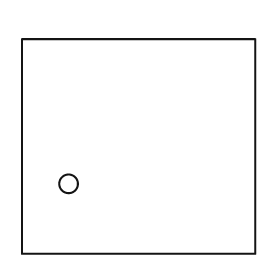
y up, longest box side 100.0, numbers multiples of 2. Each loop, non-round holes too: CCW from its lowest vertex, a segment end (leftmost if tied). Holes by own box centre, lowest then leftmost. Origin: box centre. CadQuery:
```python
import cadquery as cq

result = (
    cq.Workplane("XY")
    .moveTo(-50.0, -46.0)
    .lineTo(50.0, -46.0)
    .lineTo(50.0, 46.0)
    .lineTo(-50.0, 46.0)
    .close()
    .moveTo(-30.0, -16.0)
    .circle(4.0)
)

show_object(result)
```